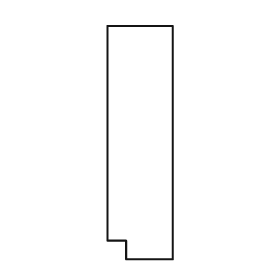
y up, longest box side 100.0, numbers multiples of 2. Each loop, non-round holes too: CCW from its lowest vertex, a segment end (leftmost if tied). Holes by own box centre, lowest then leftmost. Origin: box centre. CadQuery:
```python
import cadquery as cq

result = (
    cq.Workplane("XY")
    .moveTo(-6.0, -50.0)
    .lineTo(14.0, -50.0)
    .lineTo(14.0, 50.0)
    .lineTo(-14.0, 50.0)
    .lineTo(-14.0, -42.0)
    .lineTo(-6.0, -42.0)
    .close()
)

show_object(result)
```